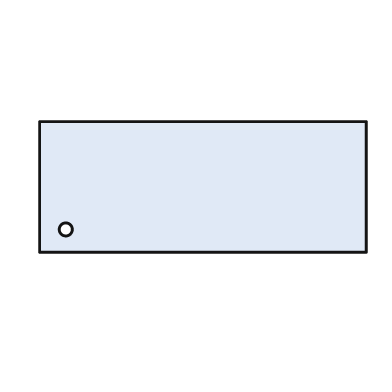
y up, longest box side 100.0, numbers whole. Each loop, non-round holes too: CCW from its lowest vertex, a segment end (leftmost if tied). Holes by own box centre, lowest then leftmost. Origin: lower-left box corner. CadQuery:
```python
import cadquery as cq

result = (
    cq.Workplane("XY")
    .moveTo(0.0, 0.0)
    .lineTo(100.0, 0.0)
    .lineTo(100.0, 40.0)
    .lineTo(0.0, 40.0)
    .close()
    .moveTo(8.0, 7.0)
    .circle(2.0)
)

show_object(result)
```